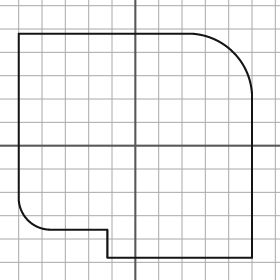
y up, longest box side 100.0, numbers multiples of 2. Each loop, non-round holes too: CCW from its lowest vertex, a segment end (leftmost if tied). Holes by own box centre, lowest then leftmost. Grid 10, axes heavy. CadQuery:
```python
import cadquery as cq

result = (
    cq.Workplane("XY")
    .moveTo(-12.0, -48.0)
    .lineTo(50.0, -48.0)
    .lineTo(50.0, 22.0)
    .threePointArc((42.0, 40.0), (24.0, 48.0))
    .lineTo(-50.0, 48.0)
    .lineTo(-50.0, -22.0)
    .threePointArc((-46.0, -32.0), (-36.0, -36.0))
    .lineTo(-12.0, -36.0)
    .close()
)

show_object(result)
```